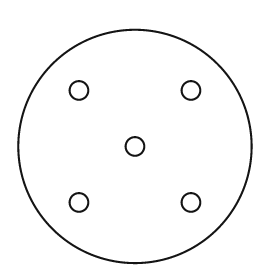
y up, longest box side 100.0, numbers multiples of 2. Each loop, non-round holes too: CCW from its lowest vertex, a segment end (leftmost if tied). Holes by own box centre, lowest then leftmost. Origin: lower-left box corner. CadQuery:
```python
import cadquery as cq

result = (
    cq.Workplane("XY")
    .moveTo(50.0, 50.0)
    .circle(50.0)
    .moveTo(26.0, 26.0)
    .circle(4.0)
    .moveTo(74.0, 26.0)
    .circle(4.0)
    .moveTo(50.0, 50.0)
    .circle(4.0)
    .moveTo(26.0, 74.0)
    .circle(4.0)
    .moveTo(74.0, 74.0)
    .circle(4.0)
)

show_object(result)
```